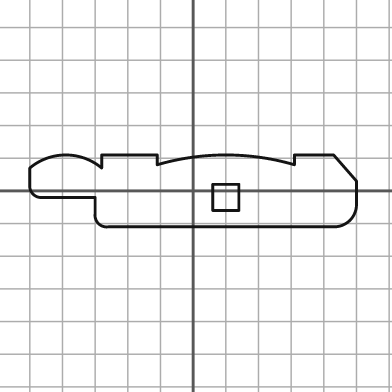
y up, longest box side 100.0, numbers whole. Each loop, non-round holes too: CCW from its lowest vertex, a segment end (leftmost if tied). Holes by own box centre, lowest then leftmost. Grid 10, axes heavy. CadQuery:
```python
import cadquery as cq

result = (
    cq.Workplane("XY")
    .moveTo(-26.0, -11.0)
    .lineTo(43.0, -11.0)
    .threePointArc((48.0, -9.0), (50.0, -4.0))
    .lineTo(50.0, 3.0)
    .lineTo(43.0, 11.0)
    .lineTo(31.0, 11.0)
    .lineTo(31.0, 8.0)
    .threePointArc((10.0, 11.0), (-11.0, 8.0))
    .lineTo(-11.0, 11.0)
    .lineTo(-28.0, 11.0)
    .lineTo(-28.0, 7.0)
    .threePointArc((-39.0, 11.0), (-50.0, 7.0))
    .lineTo(-50.0, 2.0)
    .threePointArc((-49.0, -1.0), (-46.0, -2.0))
    .lineTo(-30.0, -2.0)
    .lineTo(-30.0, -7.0)
    .threePointArc((-29.0, -10.0), (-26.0, -11.0))
    .close()
    .moveTo(6.0, -6.0)
    .lineTo(14.0, -6.0)
    .lineTo(14.0, 2.0)
    .lineTo(6.0, 2.0)
    .close()
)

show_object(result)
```